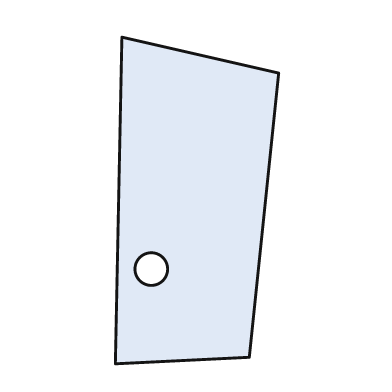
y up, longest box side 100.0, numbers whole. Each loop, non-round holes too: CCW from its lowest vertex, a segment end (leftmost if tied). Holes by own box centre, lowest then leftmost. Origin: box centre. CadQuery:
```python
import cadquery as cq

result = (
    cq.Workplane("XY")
    .moveTo(-25.0, -50.0)
    .lineTo(16.0, -48.0)
    .lineTo(25.0, 39.0)
    .lineTo(-23.0, 50.0)
    .close()
    .moveTo(-14.0, -21.0)
    .circle(5.0)
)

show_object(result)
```